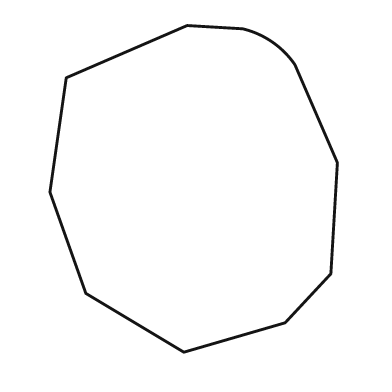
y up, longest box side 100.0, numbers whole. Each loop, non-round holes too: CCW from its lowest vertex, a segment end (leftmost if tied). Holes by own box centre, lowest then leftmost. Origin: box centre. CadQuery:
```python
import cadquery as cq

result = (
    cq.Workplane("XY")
    .moveTo(-3.0, -50.0)
    .lineTo(28.0, -41.0)
    .lineTo(42.0, -26.0)
    .lineTo(44.0, 8.0)
    .lineTo(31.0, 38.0)
    .threePointArc((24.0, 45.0), (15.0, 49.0))
    .lineTo(-2.0, 50.0)
    .lineTo(-39.0, 34.0)
    .lineTo(-44.0, -1.0)
    .lineTo(-33.0, -32.0)
    .close()
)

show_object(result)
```